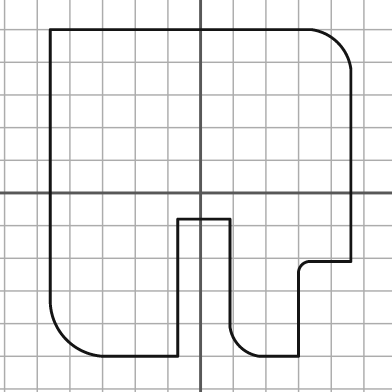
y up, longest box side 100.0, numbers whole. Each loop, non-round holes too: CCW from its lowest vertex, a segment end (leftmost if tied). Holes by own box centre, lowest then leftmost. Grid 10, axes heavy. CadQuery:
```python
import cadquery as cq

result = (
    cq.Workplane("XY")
    .moveTo(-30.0, -50.0)
    .lineTo(-7.0, -50.0)
    .lineTo(-7.0, -8.0)
    .lineTo(9.0, -8.0)
    .lineTo(9.0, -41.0)
    .threePointArc((12.0, -47.0), (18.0, -50.0))
    .lineTo(30.0, -50.0)
    .lineTo(30.0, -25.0)
    .threePointArc((31.0, -22.0), (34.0, -21.0))
    .lineTo(46.0, -21.0)
    .lineTo(46.0, 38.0)
    .threePointArc((42.0, 46.0), (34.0, 50.0))
    .lineTo(-46.0, 50.0)
    .lineTo(-46.0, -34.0)
    .threePointArc((-41.0, -45.0), (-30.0, -50.0))
    .close()
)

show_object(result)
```